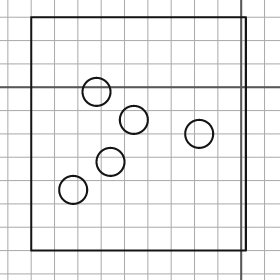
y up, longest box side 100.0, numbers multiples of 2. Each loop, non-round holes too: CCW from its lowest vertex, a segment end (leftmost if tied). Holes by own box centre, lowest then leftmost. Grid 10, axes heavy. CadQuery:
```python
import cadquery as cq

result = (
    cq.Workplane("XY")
    .moveTo(-90.0, -70.0)
    .lineTo(2.0, -70.0)
    .lineTo(2.0, 30.0)
    .lineTo(-90.0, 30.0)
    .close()
    .moveTo(-72.0, -44.0)
    .circle(6.0)
    .moveTo(-56.0, -32.0)
    .circle(6.0)
    .moveTo(-18.0, -20.0)
    .circle(6.0)
    .moveTo(-46.0, -14.0)
    .circle(6.0)
    .moveTo(-62.0, -2.0)
    .circle(6.0)
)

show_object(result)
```